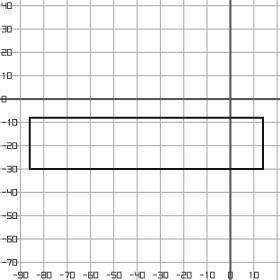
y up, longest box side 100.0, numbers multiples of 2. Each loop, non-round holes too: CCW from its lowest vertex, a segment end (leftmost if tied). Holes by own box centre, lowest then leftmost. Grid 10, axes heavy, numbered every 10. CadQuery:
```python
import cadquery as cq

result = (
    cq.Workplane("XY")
    .moveTo(-86.0, -30.0)
    .lineTo(14.0, -30.0)
    .lineTo(14.0, -8.0)
    .lineTo(-86.0, -8.0)
    .close()
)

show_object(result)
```